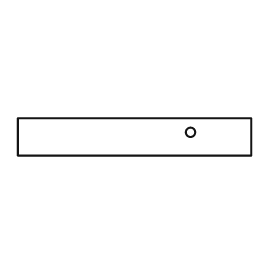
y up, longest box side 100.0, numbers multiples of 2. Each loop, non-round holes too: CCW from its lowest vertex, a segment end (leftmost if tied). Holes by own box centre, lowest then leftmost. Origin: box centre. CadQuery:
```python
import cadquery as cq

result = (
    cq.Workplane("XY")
    .moveTo(-50.0, -8.0)
    .lineTo(50.0, -8.0)
    .lineTo(50.0, 8.0)
    .lineTo(-50.0, 8.0)
    .close()
    .moveTo(24.0, 2.0)
    .circle(2.0)
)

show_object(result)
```